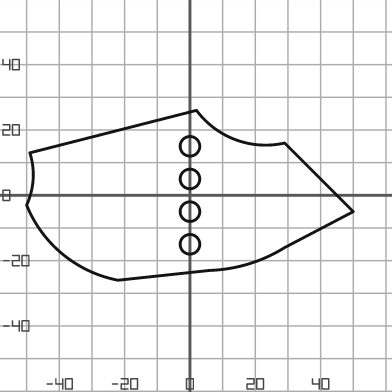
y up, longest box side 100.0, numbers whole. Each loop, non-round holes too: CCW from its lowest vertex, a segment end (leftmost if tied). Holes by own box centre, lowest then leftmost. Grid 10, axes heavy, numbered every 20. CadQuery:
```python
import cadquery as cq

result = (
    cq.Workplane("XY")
    .moveTo(-22.0, -26.0)
    .lineTo(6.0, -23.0)
    .threePointArc((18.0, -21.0), (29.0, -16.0))
    .lineTo(50.0, -5.0)
    .lineTo(29.0, 16.0)
    .threePointArc((14.0, 17.0), (2.0, 26.0))
    .lineTo(-49.0, 13.0)
    .threePointArc((-48.0, 5.0), (-50.0, -3.0))
    .threePointArc((-39.0, -18.0), (-22.0, -26.0))
    .close()
    .moveTo(0.0, -15.0)
    .circle(3.0)
    .moveTo(0.0, -5.0)
    .circle(3.0)
    .moveTo(0.0, 5.0)
    .circle(3.0)
    .moveTo(0.0, 15.0)
    .circle(3.0)
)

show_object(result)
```